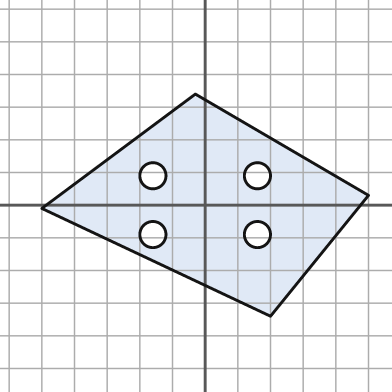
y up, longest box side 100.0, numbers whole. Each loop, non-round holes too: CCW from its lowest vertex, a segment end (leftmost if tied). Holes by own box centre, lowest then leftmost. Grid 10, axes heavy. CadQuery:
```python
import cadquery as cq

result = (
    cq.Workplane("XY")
    .moveTo(20.0, -34.0)
    .lineTo(50.0, 3.0)
    .lineTo(-3.0, 34.0)
    .lineTo(-50.0, -1.0)
    .close()
    .moveTo(-16.0, -9.0)
    .circle(4.0)
    .moveTo(16.0, -9.0)
    .circle(4.0)
    .moveTo(-16.0, 9.0)
    .circle(4.0)
    .moveTo(16.0, 9.0)
    .circle(4.0)
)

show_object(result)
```